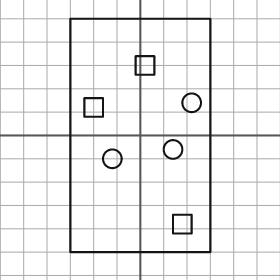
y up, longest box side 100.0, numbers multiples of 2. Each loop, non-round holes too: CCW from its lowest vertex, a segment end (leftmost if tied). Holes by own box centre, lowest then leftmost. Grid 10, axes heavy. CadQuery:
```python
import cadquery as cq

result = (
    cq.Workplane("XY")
    .moveTo(-30.0, -50.0)
    .lineTo(30.0, -50.0)
    .lineTo(30.0, 50.0)
    .lineTo(-30.0, 50.0)
    .close()
    .moveTo(14.0, -42.0)
    .lineTo(22.0, -42.0)
    .lineTo(22.0, -34.0)
    .lineTo(14.0, -34.0)
    .close()
    .moveTo(-12.0, -10.0)
    .circle(4.0)
    .moveTo(14.0, -6.0)
    .circle(4.0)
    .moveTo(-24.0, 8.0)
    .lineTo(-16.0, 8.0)
    .lineTo(-16.0, 16.0)
    .lineTo(-24.0, 16.0)
    .close()
    .moveTo(22.0, 14.0)
    .circle(4.0)
    .moveTo(-2.0, 26.0)
    .lineTo(6.0, 26.0)
    .lineTo(6.0, 34.0)
    .lineTo(-2.0, 34.0)
    .close()
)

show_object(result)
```